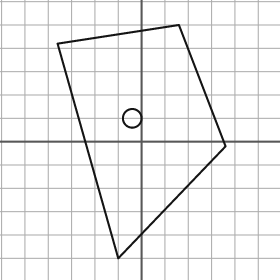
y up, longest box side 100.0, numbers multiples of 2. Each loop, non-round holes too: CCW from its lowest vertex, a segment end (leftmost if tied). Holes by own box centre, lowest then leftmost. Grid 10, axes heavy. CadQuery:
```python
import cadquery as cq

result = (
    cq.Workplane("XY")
    .moveTo(-10.0, -50.0)
    .lineTo(36.0, -2.0)
    .lineTo(16.0, 50.0)
    .lineTo(-36.0, 42.0)
    .close()
    .moveTo(-4.0, 10.0)
    .circle(4.0)
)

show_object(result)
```